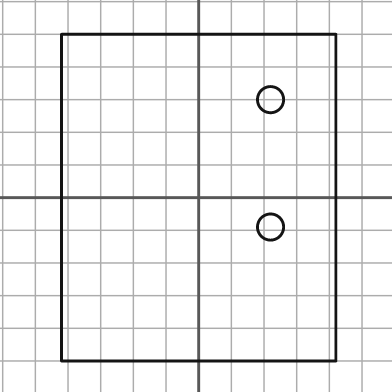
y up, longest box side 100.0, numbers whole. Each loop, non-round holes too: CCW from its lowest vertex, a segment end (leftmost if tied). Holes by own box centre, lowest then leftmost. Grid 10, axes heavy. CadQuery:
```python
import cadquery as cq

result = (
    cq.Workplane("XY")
    .moveTo(-42.0, -50.0)
    .lineTo(42.0, -50.0)
    .lineTo(42.0, 50.0)
    .lineTo(-42.0, 50.0)
    .close()
    .moveTo(22.0, -9.0)
    .circle(4.0)
    .moveTo(22.0, 30.0)
    .circle(4.0)
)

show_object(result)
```